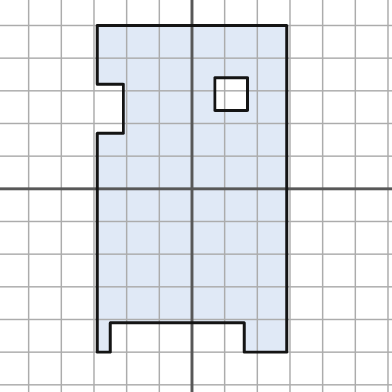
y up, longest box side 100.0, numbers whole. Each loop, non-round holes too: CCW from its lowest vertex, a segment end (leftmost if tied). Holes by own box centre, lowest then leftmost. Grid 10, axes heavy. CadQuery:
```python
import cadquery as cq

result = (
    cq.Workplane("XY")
    .moveTo(-29.0, -50.0)
    .lineTo(-25.0, -50.0)
    .lineTo(-25.0, -41.0)
    .lineTo(16.0, -41.0)
    .lineTo(16.0, -50.0)
    .lineTo(29.0, -50.0)
    .lineTo(29.0, 50.0)
    .lineTo(-29.0, 50.0)
    .lineTo(-29.0, 32.0)
    .lineTo(-21.0, 32.0)
    .lineTo(-21.0, 17.0)
    .lineTo(-29.0, 17.0)
    .close()
    .moveTo(7.0, 24.0)
    .lineTo(17.0, 24.0)
    .lineTo(17.0, 34.0)
    .lineTo(7.0, 34.0)
    .close()
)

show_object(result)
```